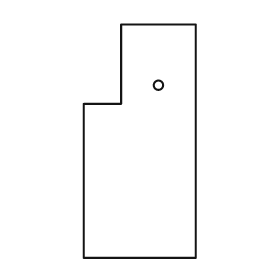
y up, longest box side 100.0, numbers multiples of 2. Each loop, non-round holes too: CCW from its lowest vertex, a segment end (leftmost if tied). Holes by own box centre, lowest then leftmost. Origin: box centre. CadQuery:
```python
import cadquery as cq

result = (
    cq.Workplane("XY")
    .moveTo(-24.0, -50.0)
    .lineTo(24.0, -50.0)
    .lineTo(24.0, 50.0)
    .lineTo(-8.0, 50.0)
    .lineTo(-8.0, 16.0)
    .lineTo(-24.0, 16.0)
    .close()
    .moveTo(8.0, 24.0)
    .circle(2.0)
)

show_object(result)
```